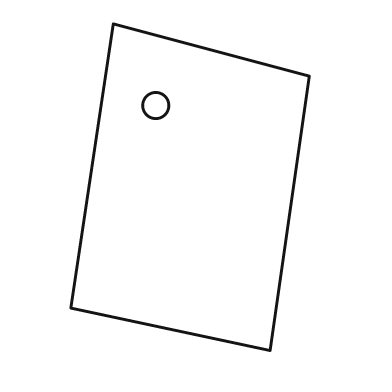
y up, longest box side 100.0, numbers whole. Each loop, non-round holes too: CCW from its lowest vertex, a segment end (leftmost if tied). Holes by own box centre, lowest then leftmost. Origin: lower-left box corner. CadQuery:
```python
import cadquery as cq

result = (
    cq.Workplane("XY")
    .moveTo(61.0, 0.0)
    .lineTo(73.0, 84.0)
    .lineTo(13.0, 100.0)
    .lineTo(0.0, 13.0)
    .close()
    .moveTo(26.0, 75.0)
    .circle(4.0)
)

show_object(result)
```